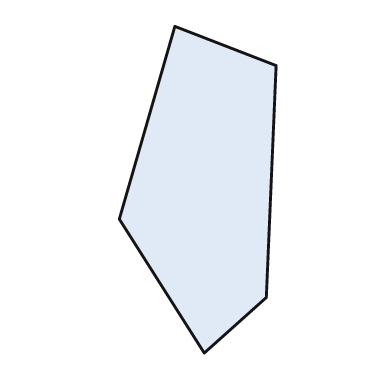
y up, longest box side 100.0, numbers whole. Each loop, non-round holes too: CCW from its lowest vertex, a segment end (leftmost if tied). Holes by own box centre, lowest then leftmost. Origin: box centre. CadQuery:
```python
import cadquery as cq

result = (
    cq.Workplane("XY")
    .moveTo(2.0, -50.0)
    .lineTo(21.0, -33.0)
    .lineTo(24.0, 38.0)
    .lineTo(-7.0, 50.0)
    .lineTo(-24.0, -9.0)
    .close()
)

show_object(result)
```